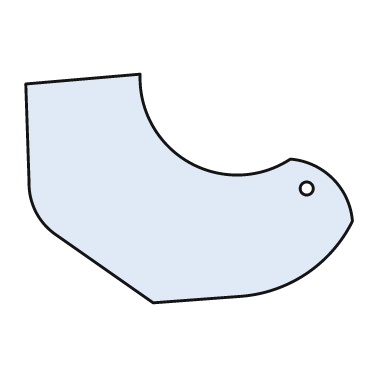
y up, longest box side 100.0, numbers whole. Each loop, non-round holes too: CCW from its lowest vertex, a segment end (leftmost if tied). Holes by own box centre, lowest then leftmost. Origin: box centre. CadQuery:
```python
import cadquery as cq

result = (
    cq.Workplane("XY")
    .moveTo(-11.0, -35.0)
    .lineTo(16.0, -33.0)
    .threePointArc((36.0, -26.0), (50.0, -10.0))
    .threePointArc((44.0, 3.0), (31.0, 9.0))
    .threePointArc((0.0, 8.0), (-15.0, 35.0))
    .lineTo(-50.0, 32.0)
    .lineTo(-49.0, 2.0)
    .threePointArc((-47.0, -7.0), (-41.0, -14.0))
    .close()
    .moveTo(36.0, 0.0)
    .circle(2.0)
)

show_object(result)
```